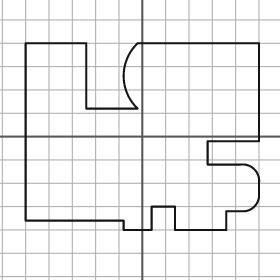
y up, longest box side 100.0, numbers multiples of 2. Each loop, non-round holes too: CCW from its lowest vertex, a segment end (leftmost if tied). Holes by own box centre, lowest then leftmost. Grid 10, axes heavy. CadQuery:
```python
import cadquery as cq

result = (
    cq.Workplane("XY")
    .moveTo(-8.0, -40.0)
    .lineTo(4.0, -40.0)
    .lineTo(4.0, -30.0)
    .lineTo(14.0, -30.0)
    .lineTo(14.0, -40.0)
    .lineTo(36.0, -40.0)
    .lineTo(36.0, -32.0)
    .lineTo(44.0, -32.0)
    .threePointArc((48.0, -30.0), (50.0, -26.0))
    .lineTo(50.0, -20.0)
    .threePointArc((48.0, -14.0), (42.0, -12.0))
    .lineTo(28.0, -12.0)
    .lineTo(28.0, -2.0)
    .lineTo(50.0, -2.0)
    .lineTo(50.0, 40.0)
    .lineTo(-2.0, 40.0)
    .threePointArc((-8.0, 26.0), (-2.0, 12.0))
    .lineTo(-24.0, 12.0)
    .lineTo(-24.0, 40.0)
    .lineTo(-50.0, 40.0)
    .lineTo(-50.0, -36.0)
    .lineTo(-8.0, -36.0)
    .close()
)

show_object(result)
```